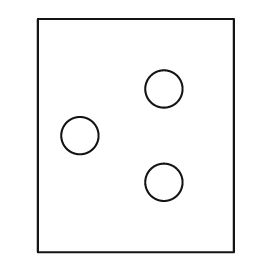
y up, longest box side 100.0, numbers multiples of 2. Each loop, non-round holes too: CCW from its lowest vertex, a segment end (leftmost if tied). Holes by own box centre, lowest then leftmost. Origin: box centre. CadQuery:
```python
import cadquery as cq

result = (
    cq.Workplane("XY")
    .moveTo(-42.0, -50.0)
    .lineTo(42.0, -50.0)
    .lineTo(42.0, 50.0)
    .lineTo(-42.0, 50.0)
    .close()
    .moveTo(12.0, -20.0)
    .circle(8.0)
    .moveTo(-24.0, 0.0)
    .circle(8.0)
    .moveTo(12.0, 20.0)
    .circle(8.0)
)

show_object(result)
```